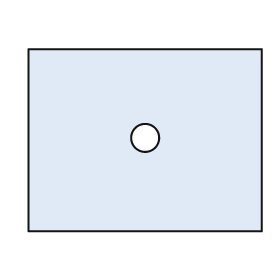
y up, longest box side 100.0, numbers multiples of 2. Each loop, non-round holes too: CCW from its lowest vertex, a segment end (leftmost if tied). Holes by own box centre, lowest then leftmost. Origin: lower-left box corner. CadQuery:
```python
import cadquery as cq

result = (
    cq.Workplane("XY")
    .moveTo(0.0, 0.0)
    .lineTo(100.0, 0.0)
    .lineTo(100.0, 78.0)
    .lineTo(0.0, 78.0)
    .close()
    .moveTo(50.0, 40.0)
    .circle(6.0)
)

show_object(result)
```